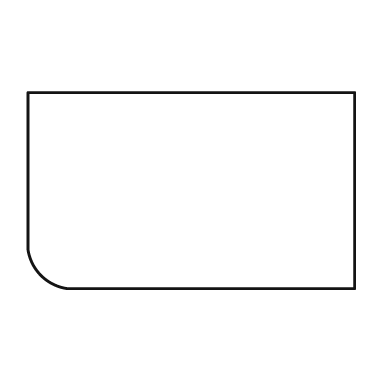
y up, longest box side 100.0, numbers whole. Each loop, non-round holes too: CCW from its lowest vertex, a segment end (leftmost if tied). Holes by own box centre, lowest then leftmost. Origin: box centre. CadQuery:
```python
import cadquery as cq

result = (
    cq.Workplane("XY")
    .moveTo(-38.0, -30.0)
    .lineTo(50.0, -30.0)
    .lineTo(50.0, 30.0)
    .lineTo(-50.0, 30.0)
    .lineTo(-50.0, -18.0)
    .threePointArc((-46.0, -26.0), (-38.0, -30.0))
    .close()
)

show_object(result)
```